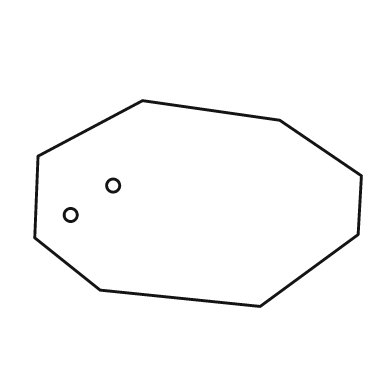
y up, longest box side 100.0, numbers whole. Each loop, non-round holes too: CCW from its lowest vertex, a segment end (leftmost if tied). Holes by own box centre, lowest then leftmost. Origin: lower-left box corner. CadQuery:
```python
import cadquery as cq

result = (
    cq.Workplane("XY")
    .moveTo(69.0, 0.0)
    .lineTo(99.0, 22.0)
    .lineTo(100.0, 40.0)
    .lineTo(75.0, 57.0)
    .lineTo(33.0, 63.0)
    .lineTo(1.0, 46.0)
    .lineTo(0.0, 21.0)
    .lineTo(20.0, 5.0)
    .close()
    .moveTo(11.0, 28.0)
    .circle(2.0)
    .moveTo(24.0, 37.0)
    .circle(2.0)
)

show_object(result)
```